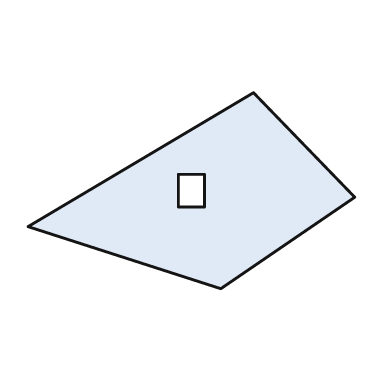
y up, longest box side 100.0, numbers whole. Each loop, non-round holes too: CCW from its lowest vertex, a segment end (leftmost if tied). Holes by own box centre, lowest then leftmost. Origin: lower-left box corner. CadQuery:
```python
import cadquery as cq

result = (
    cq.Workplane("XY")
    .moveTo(59.0, 0.0)
    .lineTo(100.0, 28.0)
    .lineTo(69.0, 60.0)
    .lineTo(0.0, 19.0)
    .close()
    .moveTo(46.0, 25.0)
    .lineTo(54.0, 25.0)
    .lineTo(54.0, 35.0)
    .lineTo(46.0, 35.0)
    .close()
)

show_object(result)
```